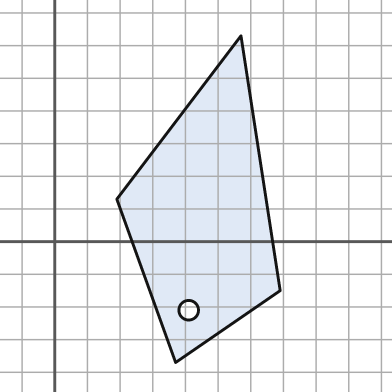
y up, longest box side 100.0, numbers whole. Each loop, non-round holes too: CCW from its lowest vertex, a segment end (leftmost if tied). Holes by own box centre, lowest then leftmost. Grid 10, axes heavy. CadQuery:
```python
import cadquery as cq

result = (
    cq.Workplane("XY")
    .moveTo(37.0, -37.0)
    .lineTo(69.0, -15.0)
    .lineTo(57.0, 63.0)
    .lineTo(19.0, 13.0)
    .close()
    .moveTo(41.0, -21.0)
    .circle(3.0)
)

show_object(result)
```